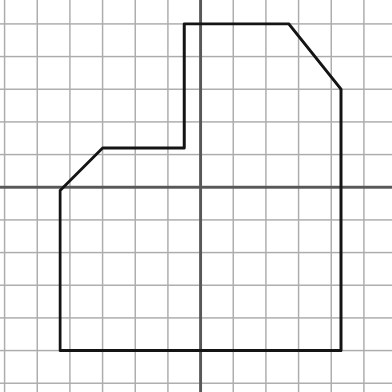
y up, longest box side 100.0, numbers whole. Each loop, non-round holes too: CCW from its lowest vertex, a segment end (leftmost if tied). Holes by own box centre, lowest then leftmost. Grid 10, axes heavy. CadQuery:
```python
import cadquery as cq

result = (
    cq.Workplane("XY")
    .moveTo(-43.0, -50.0)
    .lineTo(43.0, -50.0)
    .lineTo(43.0, 30.0)
    .lineTo(27.0, 50.0)
    .lineTo(-5.0, 50.0)
    .lineTo(-5.0, 12.0)
    .lineTo(-30.0, 12.0)
    .lineTo(-43.0, -1.0)
    .close()
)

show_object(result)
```